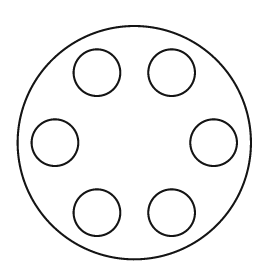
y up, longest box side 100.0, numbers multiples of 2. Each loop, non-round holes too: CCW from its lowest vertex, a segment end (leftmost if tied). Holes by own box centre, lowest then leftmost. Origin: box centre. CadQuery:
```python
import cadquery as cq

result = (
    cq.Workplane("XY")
    .moveTo(0.0, 0.0)
    .circle(50.0)
    .moveTo(-16.0, -30.0)
    .circle(10.0)
    .moveTo(16.0, -30.0)
    .circle(10.0)
    .moveTo(-34.0, 0.0)
    .circle(10.0)
    .moveTo(34.0, 0.0)
    .circle(10.0)
    .moveTo(-16.0, 30.0)
    .circle(10.0)
    .moveTo(16.0, 30.0)
    .circle(10.0)
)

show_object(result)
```